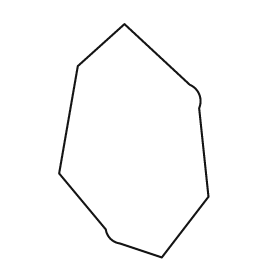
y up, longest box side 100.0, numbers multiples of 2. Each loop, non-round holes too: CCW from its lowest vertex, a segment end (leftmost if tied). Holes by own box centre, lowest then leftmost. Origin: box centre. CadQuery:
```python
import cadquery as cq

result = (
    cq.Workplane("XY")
    .moveTo(12.0, -50.0)
    .lineTo(32.0, -24.0)
    .lineTo(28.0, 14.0)
    .threePointArc((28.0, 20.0), (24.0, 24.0))
    .lineTo(-4.0, 50.0)
    .lineTo(-24.0, 32.0)
    .lineTo(-32.0, -14.0)
    .lineTo(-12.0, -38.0)
    .threePointArc((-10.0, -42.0), (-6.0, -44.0))
    .close()
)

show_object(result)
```